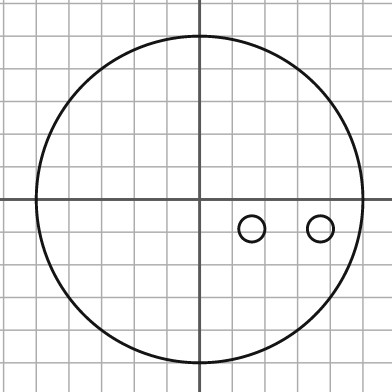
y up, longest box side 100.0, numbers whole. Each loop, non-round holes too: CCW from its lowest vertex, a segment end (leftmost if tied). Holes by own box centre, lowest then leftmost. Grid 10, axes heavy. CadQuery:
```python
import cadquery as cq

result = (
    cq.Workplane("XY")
    .moveTo(0.0, 0.0)
    .circle(50.0)
    .moveTo(16.0, -9.0)
    .circle(4.0)
    .moveTo(37.0, -9.0)
    .circle(4.0)
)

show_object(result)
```